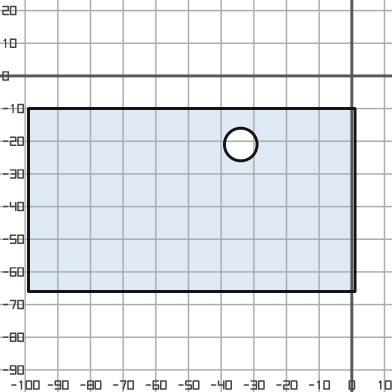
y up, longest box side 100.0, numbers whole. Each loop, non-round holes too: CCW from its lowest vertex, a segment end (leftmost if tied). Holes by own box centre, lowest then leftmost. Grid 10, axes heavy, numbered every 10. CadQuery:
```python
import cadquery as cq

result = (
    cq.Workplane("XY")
    .moveTo(-99.0, -66.0)
    .lineTo(1.0, -66.0)
    .lineTo(1.0, -10.0)
    .lineTo(-99.0, -10.0)
    .close()
    .moveTo(-34.0, -21.0)
    .circle(5.0)
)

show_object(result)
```